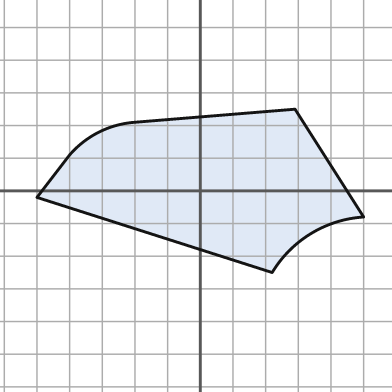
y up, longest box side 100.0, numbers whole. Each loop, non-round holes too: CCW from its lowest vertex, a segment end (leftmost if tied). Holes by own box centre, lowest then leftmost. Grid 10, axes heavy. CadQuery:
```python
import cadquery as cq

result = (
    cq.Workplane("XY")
    .moveTo(22.0, -25.0)
    .threePointArc((34.0, -13.0), (50.0, -8.0))
    .lineTo(29.0, 25.0)
    .lineTo(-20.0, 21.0)
    .threePointArc((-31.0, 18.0), (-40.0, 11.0))
    .lineTo(-50.0, -2.0)
    .close()
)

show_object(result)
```